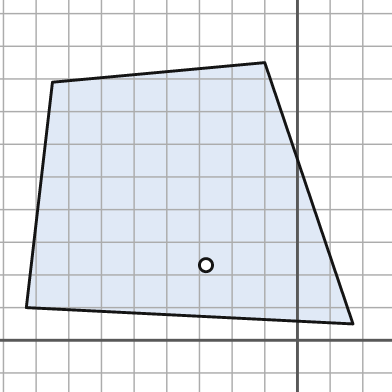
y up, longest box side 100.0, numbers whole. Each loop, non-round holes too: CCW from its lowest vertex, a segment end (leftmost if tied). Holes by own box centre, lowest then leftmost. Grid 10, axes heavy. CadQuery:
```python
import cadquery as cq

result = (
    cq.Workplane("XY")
    .moveTo(17.0, 5.0)
    .lineTo(-10.0, 85.0)
    .lineTo(-75.0, 79.0)
    .lineTo(-83.0, 10.0)
    .close()
    .moveTo(-28.0, 23.0)
    .circle(2.0)
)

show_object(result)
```